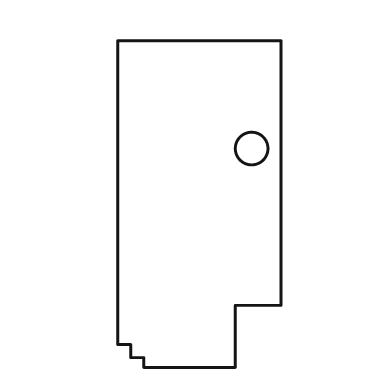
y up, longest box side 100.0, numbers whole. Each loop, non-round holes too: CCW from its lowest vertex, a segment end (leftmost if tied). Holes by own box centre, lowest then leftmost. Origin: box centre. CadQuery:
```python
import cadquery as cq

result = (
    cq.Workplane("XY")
    .moveTo(-17.0, -50.0)
    .lineTo(11.0, -50.0)
    .lineTo(11.0, -31.0)
    .lineTo(25.0, -31.0)
    .lineTo(25.0, 50.0)
    .lineTo(-25.0, 50.0)
    .lineTo(-25.0, -43.0)
    .lineTo(-21.0, -43.0)
    .lineTo(-21.0, -47.0)
    .lineTo(-17.0, -47.0)
    .close()
    .moveTo(16.0, 17.0)
    .circle(5.0)
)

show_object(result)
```